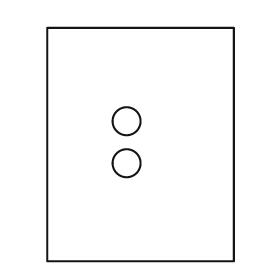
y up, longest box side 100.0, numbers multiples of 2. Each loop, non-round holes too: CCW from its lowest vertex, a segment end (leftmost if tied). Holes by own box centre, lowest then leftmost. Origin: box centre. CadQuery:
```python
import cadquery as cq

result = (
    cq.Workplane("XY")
    .moveTo(-40.0, -50.0)
    .lineTo(40.0, -50.0)
    .lineTo(40.0, 50.0)
    .lineTo(-40.0, 50.0)
    .close()
    .moveTo(-6.0, -8.0)
    .circle(6.0)
    .moveTo(-6.0, 10.0)
    .circle(6.0)
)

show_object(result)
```